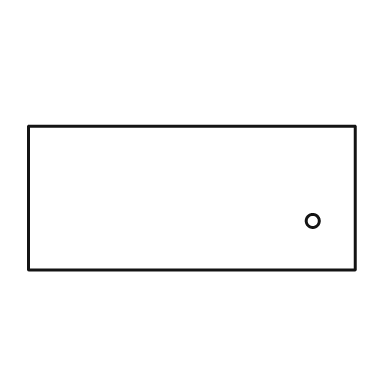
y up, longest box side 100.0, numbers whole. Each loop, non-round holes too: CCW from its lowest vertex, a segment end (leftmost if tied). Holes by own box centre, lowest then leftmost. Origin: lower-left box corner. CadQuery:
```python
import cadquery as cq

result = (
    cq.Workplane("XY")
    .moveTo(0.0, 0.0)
    .lineTo(100.0, 0.0)
    .lineTo(100.0, 44.0)
    .lineTo(0.0, 44.0)
    .close()
    .moveTo(87.0, 15.0)
    .circle(2.0)
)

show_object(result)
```